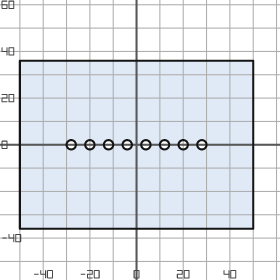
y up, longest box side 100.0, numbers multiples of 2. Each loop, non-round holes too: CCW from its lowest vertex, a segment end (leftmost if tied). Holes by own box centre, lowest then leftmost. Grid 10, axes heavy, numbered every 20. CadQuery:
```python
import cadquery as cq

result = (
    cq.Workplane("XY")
    .moveTo(-50.0, -36.0)
    .lineTo(50.0, -36.0)
    .lineTo(50.0, 36.0)
    .lineTo(-50.0, 36.0)
    .close()
    .moveTo(-28.0, 0.0)
    .circle(2.0)
    .moveTo(-20.0, 0.0)
    .circle(2.0)
    .moveTo(-12.0, 0.0)
    .circle(2.0)
    .moveTo(-4.0, 0.0)
    .circle(2.0)
    .moveTo(4.0, 0.0)
    .circle(2.0)
    .moveTo(12.0, 0.0)
    .circle(2.0)
    .moveTo(20.0, 0.0)
    .circle(2.0)
    .moveTo(28.0, 0.0)
    .circle(2.0)
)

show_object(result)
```